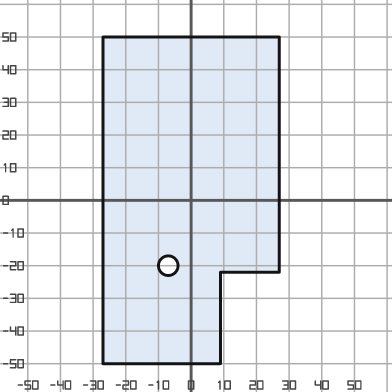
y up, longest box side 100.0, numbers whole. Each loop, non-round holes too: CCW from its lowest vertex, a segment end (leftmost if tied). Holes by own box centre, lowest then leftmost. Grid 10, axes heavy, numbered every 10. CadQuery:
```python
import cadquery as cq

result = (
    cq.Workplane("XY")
    .moveTo(-27.0, -50.0)
    .lineTo(9.0, -50.0)
    .lineTo(9.0, -22.0)
    .lineTo(27.0, -22.0)
    .lineTo(27.0, 50.0)
    .lineTo(-27.0, 50.0)
    .close()
    .moveTo(-7.0, -20.0)
    .circle(3.0)
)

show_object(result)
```